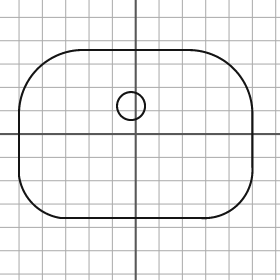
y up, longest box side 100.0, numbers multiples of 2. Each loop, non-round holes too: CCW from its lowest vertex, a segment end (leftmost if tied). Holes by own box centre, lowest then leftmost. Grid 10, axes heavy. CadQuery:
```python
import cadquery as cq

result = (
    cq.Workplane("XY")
    .moveTo(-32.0, -36.0)
    .lineTo(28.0, -36.0)
    .threePointArc((44.0, -30.0), (50.0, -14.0))
    .lineTo(50.0, 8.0)
    .threePointArc((42.0, 28.0), (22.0, 36.0))
    .lineTo(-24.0, 36.0)
    .threePointArc((-42.0, 28.0), (-50.0, 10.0))
    .lineTo(-50.0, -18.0)
    .threePointArc((-44.0, -30.0), (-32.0, -36.0))
    .close()
    .moveTo(-2.0, 12.0)
    .circle(6.0)
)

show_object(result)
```